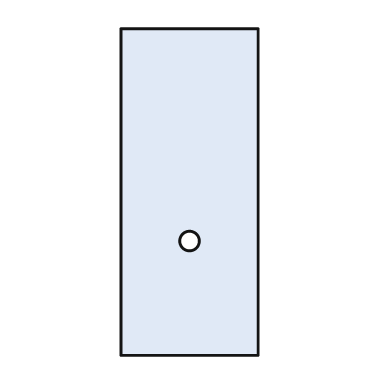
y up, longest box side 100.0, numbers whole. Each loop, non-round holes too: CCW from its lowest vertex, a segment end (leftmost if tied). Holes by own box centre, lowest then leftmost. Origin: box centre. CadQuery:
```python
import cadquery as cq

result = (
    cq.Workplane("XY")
    .moveTo(-21.0, -50.0)
    .lineTo(21.0, -50.0)
    .lineTo(21.0, 50.0)
    .lineTo(-21.0, 50.0)
    .close()
    .moveTo(0.0, -15.0)
    .circle(3.0)
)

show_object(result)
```